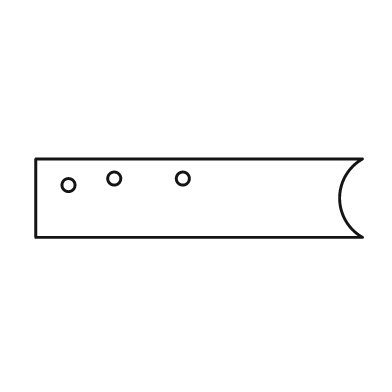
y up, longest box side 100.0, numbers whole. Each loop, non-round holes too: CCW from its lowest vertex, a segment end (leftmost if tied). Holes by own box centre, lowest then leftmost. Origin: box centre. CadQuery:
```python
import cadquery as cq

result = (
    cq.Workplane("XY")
    .moveTo(-50.0, -12.0)
    .lineTo(50.0, -12.0)
    .threePointArc((43.0, 0.0), (50.0, 12.0))
    .lineTo(-50.0, 12.0)
    .close()
    .moveTo(-40.0, 4.0)
    .circle(2.0)
    .moveTo(-26.0, 6.0)
    .circle(2.0)
    .moveTo(-5.0, 6.0)
    .circle(2.0)
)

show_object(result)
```